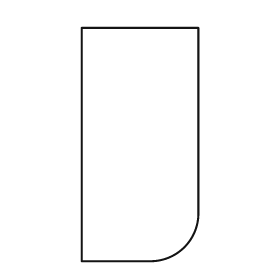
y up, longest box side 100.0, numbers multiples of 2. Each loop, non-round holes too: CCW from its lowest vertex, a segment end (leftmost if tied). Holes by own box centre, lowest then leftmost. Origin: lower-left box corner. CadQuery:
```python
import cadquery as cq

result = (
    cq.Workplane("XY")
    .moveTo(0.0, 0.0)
    .lineTo(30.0, 0.0)
    .threePointArc((44.0, 6.0), (50.0, 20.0))
    .lineTo(50.0, 100.0)
    .lineTo(0.0, 100.0)
    .close()
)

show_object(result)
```